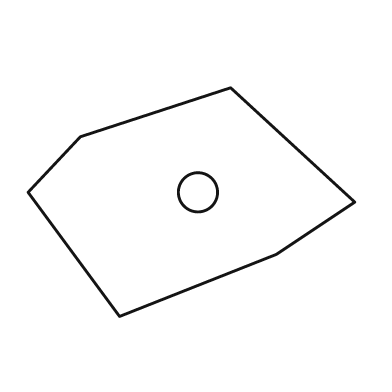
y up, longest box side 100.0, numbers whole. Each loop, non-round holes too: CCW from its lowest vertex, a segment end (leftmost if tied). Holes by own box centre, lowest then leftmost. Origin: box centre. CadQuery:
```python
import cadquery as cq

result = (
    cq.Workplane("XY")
    .moveTo(-22.0, -35.0)
    .lineTo(26.0, -16.0)
    .lineTo(50.0, 0.0)
    .lineTo(12.0, 35.0)
    .lineTo(-34.0, 20.0)
    .lineTo(-50.0, 3.0)
    .close()
    .moveTo(2.0, 3.0)
    .circle(6.0)
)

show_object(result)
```